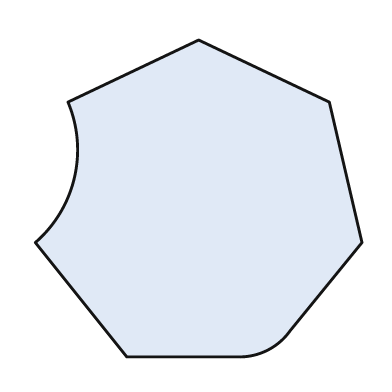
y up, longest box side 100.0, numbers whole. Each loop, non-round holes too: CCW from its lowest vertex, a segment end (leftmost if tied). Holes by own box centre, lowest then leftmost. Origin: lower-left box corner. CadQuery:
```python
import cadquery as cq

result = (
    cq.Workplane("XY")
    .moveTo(28.0, 0.0)
    .lineTo(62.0, 0.0)
    .threePointArc((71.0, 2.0), (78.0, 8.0))
    .lineTo(100.0, 35.0)
    .lineTo(90.0, 78.0)
    .lineTo(50.0, 97.0)
    .lineTo(10.0, 78.0)
    .threePointArc((12.0, 55.0), (0.0, 35.0))
    .close()
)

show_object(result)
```